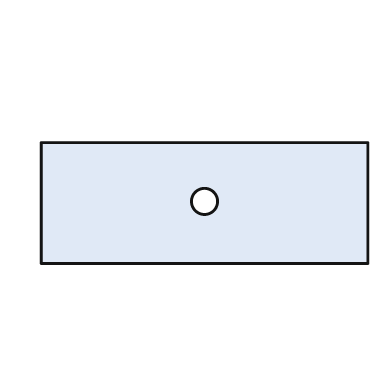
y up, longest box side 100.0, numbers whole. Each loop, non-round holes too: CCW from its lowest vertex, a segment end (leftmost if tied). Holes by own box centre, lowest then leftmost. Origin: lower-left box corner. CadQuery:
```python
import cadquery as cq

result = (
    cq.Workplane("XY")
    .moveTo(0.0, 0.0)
    .lineTo(100.0, 0.0)
    .lineTo(100.0, 37.0)
    .lineTo(0.0, 37.0)
    .close()
    .moveTo(50.0, 19.0)
    .circle(4.0)
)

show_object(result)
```